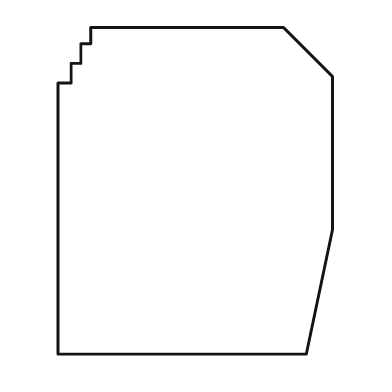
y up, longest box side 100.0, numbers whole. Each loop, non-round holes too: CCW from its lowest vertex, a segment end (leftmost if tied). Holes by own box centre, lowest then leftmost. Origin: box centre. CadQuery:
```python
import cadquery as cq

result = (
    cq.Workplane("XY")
    .moveTo(-42.0, -50.0)
    .lineTo(34.0, -50.0)
    .lineTo(42.0, -12.0)
    .lineTo(42.0, 35.0)
    .lineTo(27.0, 50.0)
    .lineTo(-32.0, 50.0)
    .lineTo(-32.0, 45.0)
    .lineTo(-35.0, 45.0)
    .lineTo(-35.0, 39.0)
    .lineTo(-38.0, 39.0)
    .lineTo(-38.0, 33.0)
    .lineTo(-42.0, 33.0)
    .close()
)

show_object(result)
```